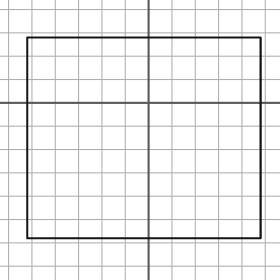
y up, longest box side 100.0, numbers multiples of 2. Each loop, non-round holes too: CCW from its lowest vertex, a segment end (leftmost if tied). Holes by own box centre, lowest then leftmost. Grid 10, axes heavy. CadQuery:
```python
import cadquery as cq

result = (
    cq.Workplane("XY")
    .moveTo(-52.0, -58.0)
    .lineTo(48.0, -58.0)
    .lineTo(48.0, 28.0)
    .lineTo(-52.0, 28.0)
    .close()
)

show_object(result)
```